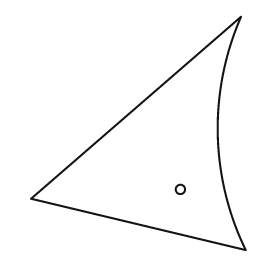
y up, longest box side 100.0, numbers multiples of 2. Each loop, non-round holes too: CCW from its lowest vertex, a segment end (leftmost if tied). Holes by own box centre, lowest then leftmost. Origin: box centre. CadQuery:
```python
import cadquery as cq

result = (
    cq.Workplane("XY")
    .moveTo(46.0, -50.0)
    .threePointArc((34.0, 0.0), (44.0, 50.0))
    .lineTo(-46.0, -28.0)
    .close()
    .moveTo(18.0, -24.0)
    .circle(2.0)
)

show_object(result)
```